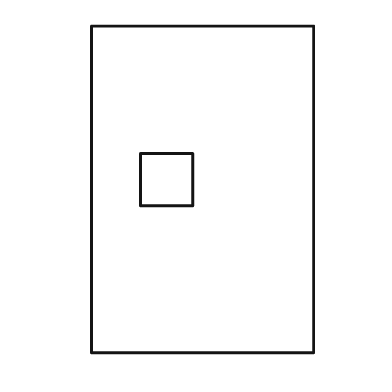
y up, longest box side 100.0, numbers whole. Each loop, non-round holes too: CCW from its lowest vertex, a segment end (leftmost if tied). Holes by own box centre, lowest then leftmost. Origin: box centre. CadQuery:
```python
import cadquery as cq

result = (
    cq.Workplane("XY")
    .moveTo(-34.0, -50.0)
    .lineTo(34.0, -50.0)
    .lineTo(34.0, 50.0)
    .lineTo(-34.0, 50.0)
    .close()
    .moveTo(-19.0, -5.0)
    .lineTo(-3.0, -5.0)
    .lineTo(-3.0, 11.0)
    .lineTo(-19.0, 11.0)
    .close()
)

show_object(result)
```